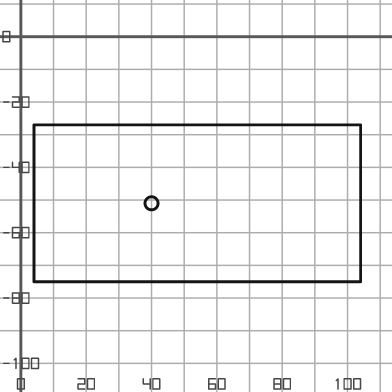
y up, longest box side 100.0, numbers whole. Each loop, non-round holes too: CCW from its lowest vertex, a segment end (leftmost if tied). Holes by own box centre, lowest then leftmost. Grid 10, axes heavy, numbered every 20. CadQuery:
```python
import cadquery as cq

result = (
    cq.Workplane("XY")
    .moveTo(4.0, -75.0)
    .lineTo(104.0, -75.0)
    .lineTo(104.0, -27.0)
    .lineTo(4.0, -27.0)
    .close()
    .moveTo(40.0, -51.0)
    .circle(2.0)
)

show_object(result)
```